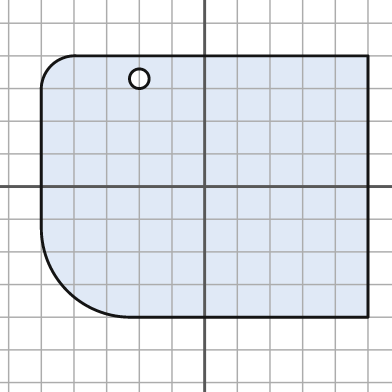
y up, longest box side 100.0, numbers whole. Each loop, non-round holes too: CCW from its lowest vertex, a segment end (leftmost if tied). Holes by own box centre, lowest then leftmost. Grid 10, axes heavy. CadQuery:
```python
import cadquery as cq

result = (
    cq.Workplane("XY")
    .moveTo(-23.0, -40.0)
    .lineTo(50.0, -40.0)
    .lineTo(50.0, 40.0)
    .lineTo(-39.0, 40.0)
    .threePointArc((-47.0, 37.0), (-50.0, 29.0))
    .lineTo(-50.0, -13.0)
    .threePointArc((-42.0, -32.0), (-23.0, -40.0))
    .close()
    .moveTo(-20.0, 33.0)
    .circle(3.0)
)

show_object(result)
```